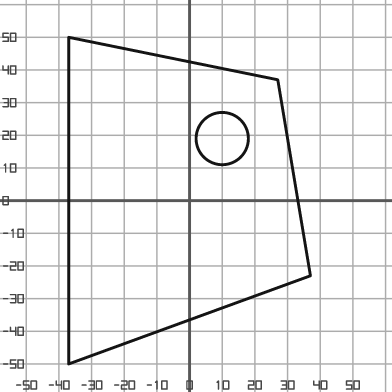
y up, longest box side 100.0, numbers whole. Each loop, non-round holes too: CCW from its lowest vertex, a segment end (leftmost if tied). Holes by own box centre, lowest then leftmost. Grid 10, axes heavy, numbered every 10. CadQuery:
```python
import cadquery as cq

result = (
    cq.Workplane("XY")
    .moveTo(-37.0, -50.0)
    .lineTo(37.0, -23.0)
    .lineTo(27.0, 37.0)
    .lineTo(-37.0, 50.0)
    .close()
    .moveTo(10.0, 19.0)
    .circle(8.0)
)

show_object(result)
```